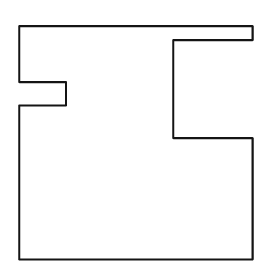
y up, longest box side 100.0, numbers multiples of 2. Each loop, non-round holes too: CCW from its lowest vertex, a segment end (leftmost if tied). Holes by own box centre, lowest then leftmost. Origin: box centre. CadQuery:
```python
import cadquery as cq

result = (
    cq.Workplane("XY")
    .moveTo(-50.0, -50.0)
    .lineTo(50.0, -50.0)
    .lineTo(50.0, 2.0)
    .lineTo(16.0, 2.0)
    .lineTo(16.0, 44.0)
    .lineTo(50.0, 44.0)
    .lineTo(50.0, 50.0)
    .lineTo(-50.0, 50.0)
    .lineTo(-50.0, 26.0)
    .lineTo(-30.0, 26.0)
    .lineTo(-30.0, 16.0)
    .lineTo(-50.0, 16.0)
    .close()
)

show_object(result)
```